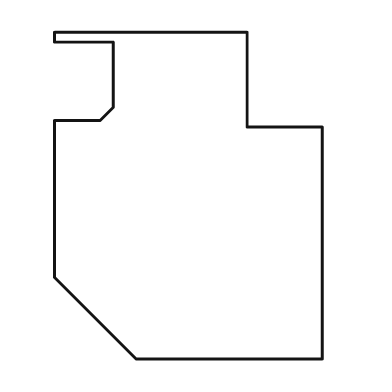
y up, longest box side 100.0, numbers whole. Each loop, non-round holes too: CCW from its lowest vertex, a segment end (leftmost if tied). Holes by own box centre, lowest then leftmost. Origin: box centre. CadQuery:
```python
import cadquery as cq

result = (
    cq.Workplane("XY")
    .moveTo(-16.0, -50.0)
    .lineTo(41.0, -50.0)
    .lineTo(41.0, 21.0)
    .lineTo(18.0, 21.0)
    .lineTo(18.0, 50.0)
    .lineTo(-41.0, 50.0)
    .lineTo(-41.0, 47.0)
    .lineTo(-23.0, 47.0)
    .lineTo(-23.0, 27.0)
    .lineTo(-27.0, 23.0)
    .lineTo(-41.0, 23.0)
    .lineTo(-41.0, -25.0)
    .close()
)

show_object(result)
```